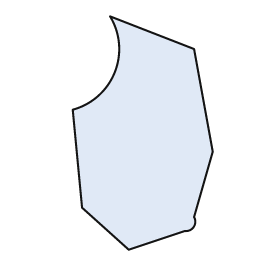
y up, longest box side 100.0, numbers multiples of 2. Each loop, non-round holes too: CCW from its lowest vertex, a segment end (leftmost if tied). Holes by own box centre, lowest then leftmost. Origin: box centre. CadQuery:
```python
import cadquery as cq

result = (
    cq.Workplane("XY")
    .moveTo(-6.0, -50.0)
    .lineTo(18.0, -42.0)
    .threePointArc((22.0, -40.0), (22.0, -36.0))
    .lineTo(30.0, -8.0)
    .lineTo(22.0, 36.0)
    .lineTo(-14.0, 50.0)
    .threePointArc((-12.0, 26.0), (-30.0, 10.0))
    .lineTo(-26.0, -32.0)
    .close()
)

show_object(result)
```